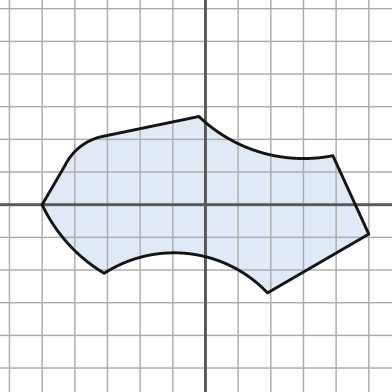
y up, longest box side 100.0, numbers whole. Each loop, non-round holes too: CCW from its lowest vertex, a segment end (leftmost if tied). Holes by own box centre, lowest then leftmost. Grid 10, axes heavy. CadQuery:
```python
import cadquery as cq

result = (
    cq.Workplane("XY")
    .moveTo(19.0, -27.0)
    .lineTo(50.0, -9.0)
    .lineTo(39.0, 15.0)
    .threePointArc((17.0, 16.0), (-2.0, 27.0))
    .lineTo(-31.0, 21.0)
    .threePointArc((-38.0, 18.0), (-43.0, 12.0))
    .lineTo(-50.0, 0.0)
    .threePointArc((-42.0, -12.0), (-31.0, -21.0))
    .threePointArc((-5.0, -15.0), (19.0, -27.0))
    .close()
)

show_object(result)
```